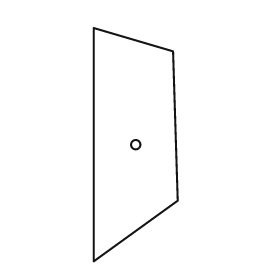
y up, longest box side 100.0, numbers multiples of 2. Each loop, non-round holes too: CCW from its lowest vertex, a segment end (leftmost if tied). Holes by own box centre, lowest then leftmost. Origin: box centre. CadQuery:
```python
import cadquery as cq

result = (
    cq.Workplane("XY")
    .moveTo(-18.0, -50.0)
    .lineTo(18.0, -24.0)
    .lineTo(16.0, 40.0)
    .lineTo(-18.0, 50.0)
    .close()
    .moveTo(0.0, 0.0)
    .circle(2.0)
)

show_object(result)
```